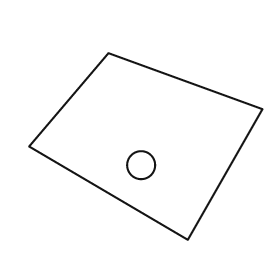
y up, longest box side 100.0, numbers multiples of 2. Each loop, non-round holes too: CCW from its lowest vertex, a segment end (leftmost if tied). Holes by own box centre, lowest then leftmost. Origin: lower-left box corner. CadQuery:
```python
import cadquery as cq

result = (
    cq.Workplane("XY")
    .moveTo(68.0, 0.0)
    .lineTo(100.0, 56.0)
    .lineTo(34.0, 80.0)
    .lineTo(0.0, 40.0)
    .close()
    .moveTo(48.0, 32.0)
    .circle(6.0)
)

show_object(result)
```